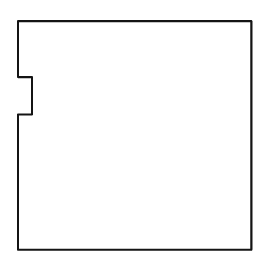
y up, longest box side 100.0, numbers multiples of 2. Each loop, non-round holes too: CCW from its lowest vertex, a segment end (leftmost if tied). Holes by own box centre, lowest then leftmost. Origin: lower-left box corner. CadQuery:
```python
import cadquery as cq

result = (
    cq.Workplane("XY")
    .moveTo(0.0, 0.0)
    .lineTo(100.0, 0.0)
    .lineTo(100.0, 98.0)
    .lineTo(0.0, 98.0)
    .lineTo(0.0, 74.0)
    .lineTo(6.0, 74.0)
    .lineTo(6.0, 58.0)
    .lineTo(0.0, 58.0)
    .close()
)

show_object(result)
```